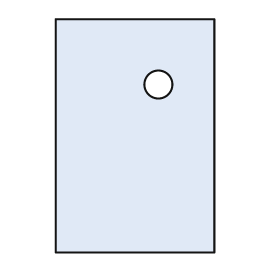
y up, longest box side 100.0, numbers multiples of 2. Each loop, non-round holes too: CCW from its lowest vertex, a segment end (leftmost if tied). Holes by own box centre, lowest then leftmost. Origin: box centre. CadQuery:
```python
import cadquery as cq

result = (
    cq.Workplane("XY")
    .moveTo(-34.0, -50.0)
    .lineTo(34.0, -50.0)
    .lineTo(34.0, 50.0)
    .lineTo(-34.0, 50.0)
    .close()
    .moveTo(10.0, 22.0)
    .circle(6.0)
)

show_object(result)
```